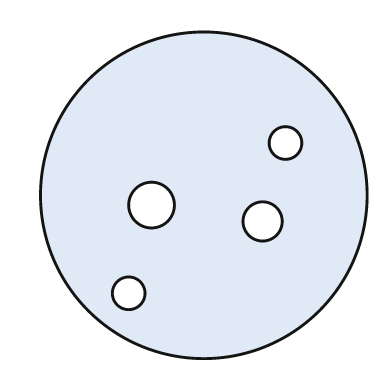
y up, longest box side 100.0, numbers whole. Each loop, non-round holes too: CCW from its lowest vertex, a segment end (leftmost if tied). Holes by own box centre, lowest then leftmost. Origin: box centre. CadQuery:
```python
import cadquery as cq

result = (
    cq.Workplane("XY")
    .moveTo(0.0, 0.0)
    .circle(50.0)
    .moveTo(-23.0, -30.0)
    .circle(5.0)
    .moveTo(18.0, -8.0)
    .circle(6.0)
    .moveTo(-16.0, -3.0)
    .circle(7.0)
    .moveTo(25.0, 16.0)
    .circle(5.0)
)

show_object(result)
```